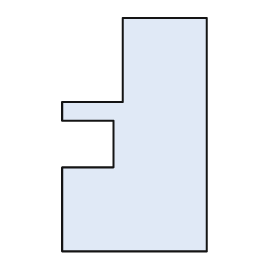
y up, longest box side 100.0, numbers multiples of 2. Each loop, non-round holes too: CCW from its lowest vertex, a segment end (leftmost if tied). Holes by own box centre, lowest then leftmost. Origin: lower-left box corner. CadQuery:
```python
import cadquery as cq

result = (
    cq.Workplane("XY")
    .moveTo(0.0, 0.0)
    .lineTo(62.0, 0.0)
    .lineTo(62.0, 100.0)
    .lineTo(26.0, 100.0)
    .lineTo(26.0, 64.0)
    .lineTo(0.0, 64.0)
    .lineTo(0.0, 56.0)
    .lineTo(22.0, 56.0)
    .lineTo(22.0, 36.0)
    .lineTo(0.0, 36.0)
    .close()
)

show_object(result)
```